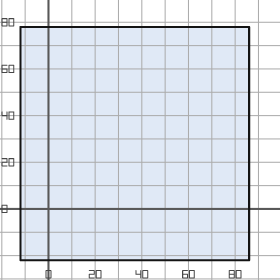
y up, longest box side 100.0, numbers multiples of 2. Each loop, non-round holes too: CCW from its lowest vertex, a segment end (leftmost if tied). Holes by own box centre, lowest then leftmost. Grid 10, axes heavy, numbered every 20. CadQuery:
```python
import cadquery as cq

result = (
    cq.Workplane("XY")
    .moveTo(-12.0, -22.0)
    .lineTo(86.0, -22.0)
    .lineTo(86.0, 78.0)
    .lineTo(-12.0, 78.0)
    .close()
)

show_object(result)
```